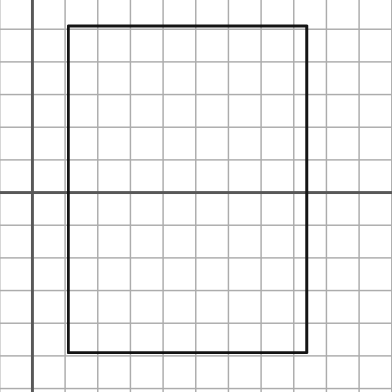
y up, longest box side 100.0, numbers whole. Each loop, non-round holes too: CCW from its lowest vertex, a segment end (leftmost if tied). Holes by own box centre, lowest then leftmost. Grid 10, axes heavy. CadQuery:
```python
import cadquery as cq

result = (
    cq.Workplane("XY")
    .moveTo(11.0, -49.0)
    .lineTo(84.0, -49.0)
    .lineTo(84.0, 51.0)
    .lineTo(11.0, 51.0)
    .close()
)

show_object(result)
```